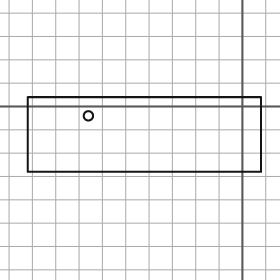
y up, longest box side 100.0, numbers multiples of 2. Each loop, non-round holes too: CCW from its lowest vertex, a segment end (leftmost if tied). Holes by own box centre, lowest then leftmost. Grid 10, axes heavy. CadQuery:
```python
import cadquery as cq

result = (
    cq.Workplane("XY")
    .moveTo(-92.0, -28.0)
    .lineTo(8.0, -28.0)
    .lineTo(8.0, 4.0)
    .lineTo(-92.0, 4.0)
    .close()
    .moveTo(-66.0, -4.0)
    .circle(2.0)
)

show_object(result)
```